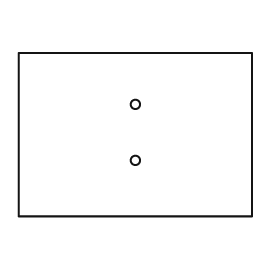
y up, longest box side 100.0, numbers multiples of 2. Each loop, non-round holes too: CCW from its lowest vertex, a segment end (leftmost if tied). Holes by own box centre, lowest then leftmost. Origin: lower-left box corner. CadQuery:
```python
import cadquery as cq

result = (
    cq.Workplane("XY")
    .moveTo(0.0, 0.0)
    .lineTo(100.0, 0.0)
    .lineTo(100.0, 70.0)
    .lineTo(0.0, 70.0)
    .close()
    .moveTo(50.0, 24.0)
    .circle(2.0)
    .moveTo(50.0, 48.0)
    .circle(2.0)
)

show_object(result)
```